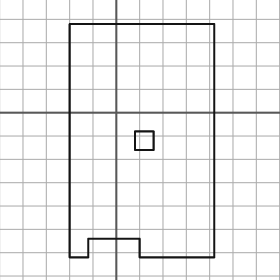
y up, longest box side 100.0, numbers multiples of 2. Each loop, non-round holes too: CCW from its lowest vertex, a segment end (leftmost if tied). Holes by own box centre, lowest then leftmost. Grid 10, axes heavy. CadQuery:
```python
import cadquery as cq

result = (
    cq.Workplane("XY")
    .moveTo(-20.0, -62.0)
    .lineTo(-12.0, -62.0)
    .lineTo(-12.0, -54.0)
    .lineTo(10.0, -54.0)
    .lineTo(10.0, -62.0)
    .lineTo(42.0, -62.0)
    .lineTo(42.0, 38.0)
    .lineTo(-20.0, 38.0)
    .close()
    .moveTo(8.0, -16.0)
    .lineTo(16.0, -16.0)
    .lineTo(16.0, -8.0)
    .lineTo(8.0, -8.0)
    .close()
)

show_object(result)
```